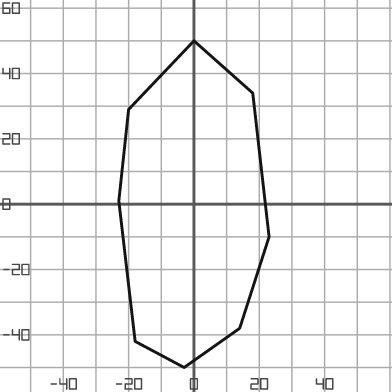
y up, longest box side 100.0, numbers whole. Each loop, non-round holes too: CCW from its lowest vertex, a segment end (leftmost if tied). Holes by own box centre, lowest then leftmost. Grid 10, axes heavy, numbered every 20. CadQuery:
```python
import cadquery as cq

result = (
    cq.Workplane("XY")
    .moveTo(-3.0, -50.0)
    .lineTo(14.0, -38.0)
    .lineTo(23.0, -10.0)
    .lineTo(18.0, 34.0)
    .lineTo(0.0, 50.0)
    .lineTo(-20.0, 29.0)
    .lineTo(-23.0, 1.0)
    .lineTo(-18.0, -42.0)
    .close()
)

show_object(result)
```